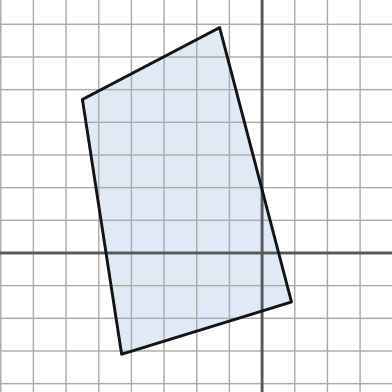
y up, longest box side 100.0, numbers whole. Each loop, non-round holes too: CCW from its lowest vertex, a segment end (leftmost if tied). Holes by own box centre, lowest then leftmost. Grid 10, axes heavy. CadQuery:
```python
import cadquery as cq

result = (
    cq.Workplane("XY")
    .moveTo(-43.0, -31.0)
    .lineTo(9.0, -15.0)
    .lineTo(-13.0, 69.0)
    .lineTo(-55.0, 47.0)
    .close()
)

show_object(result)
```